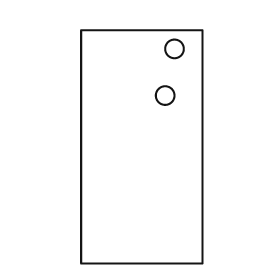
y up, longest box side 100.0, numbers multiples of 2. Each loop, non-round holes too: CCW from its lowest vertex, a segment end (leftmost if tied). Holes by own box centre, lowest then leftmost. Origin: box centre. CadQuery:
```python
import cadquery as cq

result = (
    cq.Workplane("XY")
    .moveTo(-26.0, -50.0)
    .lineTo(26.0, -50.0)
    .lineTo(26.0, 50.0)
    .lineTo(-26.0, 50.0)
    .close()
    .moveTo(10.0, 22.0)
    .circle(4.0)
    .moveTo(14.0, 42.0)
    .circle(4.0)
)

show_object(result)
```